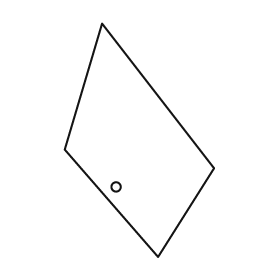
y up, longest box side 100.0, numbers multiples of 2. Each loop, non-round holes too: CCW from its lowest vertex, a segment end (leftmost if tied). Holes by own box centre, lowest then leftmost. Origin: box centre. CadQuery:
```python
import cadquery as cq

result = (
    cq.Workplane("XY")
    .moveTo(8.0, -50.0)
    .lineTo(32.0, -12.0)
    .lineTo(-16.0, 50.0)
    .lineTo(-32.0, -4.0)
    .close()
    .moveTo(-10.0, -20.0)
    .circle(2.0)
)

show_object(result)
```